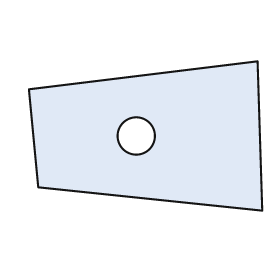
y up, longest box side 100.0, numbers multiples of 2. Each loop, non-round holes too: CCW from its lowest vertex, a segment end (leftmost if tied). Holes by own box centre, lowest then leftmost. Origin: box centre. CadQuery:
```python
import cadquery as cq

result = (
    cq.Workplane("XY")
    .moveTo(50.0, -32.0)
    .lineTo(48.0, 32.0)
    .lineTo(-50.0, 20.0)
    .lineTo(-46.0, -22.0)
    .close()
    .moveTo(-4.0, 0.0)
    .circle(8.0)
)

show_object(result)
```